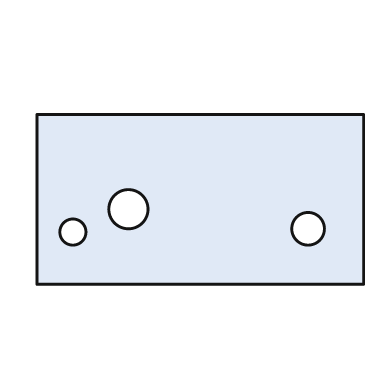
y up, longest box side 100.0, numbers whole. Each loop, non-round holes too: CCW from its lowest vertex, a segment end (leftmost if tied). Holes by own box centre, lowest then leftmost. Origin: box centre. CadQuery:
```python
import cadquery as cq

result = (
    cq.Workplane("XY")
    .moveTo(-50.0, -26.0)
    .lineTo(50.0, -26.0)
    .lineTo(50.0, 26.0)
    .lineTo(-50.0, 26.0)
    .close()
    .moveTo(-39.0, -10.0)
    .circle(4.0)
    .moveTo(33.0, -9.0)
    .circle(5.0)
    .moveTo(-22.0, -3.0)
    .circle(6.0)
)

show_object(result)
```